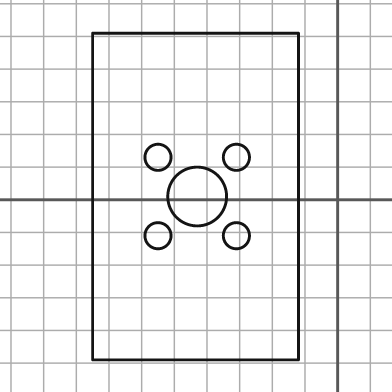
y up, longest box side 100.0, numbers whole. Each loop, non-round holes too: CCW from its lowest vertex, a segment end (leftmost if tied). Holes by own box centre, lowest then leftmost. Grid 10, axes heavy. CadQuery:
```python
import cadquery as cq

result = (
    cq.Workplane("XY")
    .moveTo(-75.0, -49.0)
    .lineTo(-12.0, -49.0)
    .lineTo(-12.0, 51.0)
    .lineTo(-75.0, 51.0)
    .close()
    .moveTo(-55.0, -11.0)
    .circle(4.0)
    .moveTo(-31.0, -11.0)
    .circle(4.0)
    .moveTo(-43.0, 1.0)
    .circle(9.0)
    .moveTo(-55.0, 13.0)
    .circle(4.0)
    .moveTo(-31.0, 13.0)
    .circle(4.0)
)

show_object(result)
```